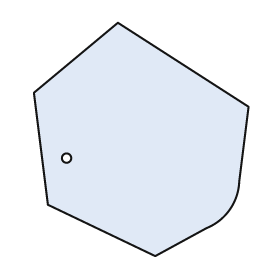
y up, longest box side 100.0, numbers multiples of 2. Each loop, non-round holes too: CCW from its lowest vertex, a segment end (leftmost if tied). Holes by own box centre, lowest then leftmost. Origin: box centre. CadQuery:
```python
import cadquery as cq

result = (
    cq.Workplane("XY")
    .moveTo(6.0, -50.0)
    .lineTo(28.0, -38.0)
    .threePointArc((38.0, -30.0), (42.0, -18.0))
    .lineTo(46.0, 14.0)
    .lineTo(-10.0, 50.0)
    .lineTo(-46.0, 20.0)
    .lineTo(-40.0, -28.0)
    .close()
    .moveTo(-32.0, -8.0)
    .circle(2.0)
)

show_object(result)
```